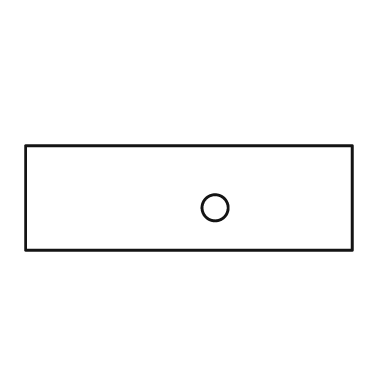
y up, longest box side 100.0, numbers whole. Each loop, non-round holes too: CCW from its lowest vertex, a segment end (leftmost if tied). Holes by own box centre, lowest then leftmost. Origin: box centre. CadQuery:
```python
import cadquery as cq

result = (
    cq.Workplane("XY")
    .moveTo(-50.0, -16.0)
    .lineTo(50.0, -16.0)
    .lineTo(50.0, 16.0)
    .lineTo(-50.0, 16.0)
    .close()
    .moveTo(8.0, -3.0)
    .circle(4.0)
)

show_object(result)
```